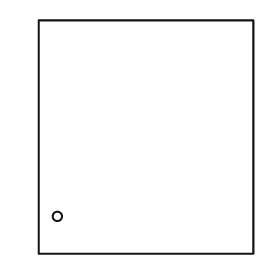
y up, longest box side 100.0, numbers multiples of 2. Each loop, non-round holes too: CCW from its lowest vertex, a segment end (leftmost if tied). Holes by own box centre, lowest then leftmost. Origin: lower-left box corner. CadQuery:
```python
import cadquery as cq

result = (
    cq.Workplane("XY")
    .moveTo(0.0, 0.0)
    .lineTo(92.0, 0.0)
    .lineTo(92.0, 100.0)
    .lineTo(0.0, 100.0)
    .close()
    .moveTo(8.0, 16.0)
    .circle(2.0)
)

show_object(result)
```